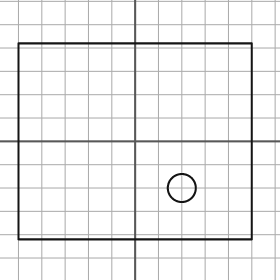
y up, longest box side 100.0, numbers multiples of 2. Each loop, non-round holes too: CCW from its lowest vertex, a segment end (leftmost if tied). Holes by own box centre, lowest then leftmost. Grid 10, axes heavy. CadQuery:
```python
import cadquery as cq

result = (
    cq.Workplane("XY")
    .moveTo(-50.0, -42.0)
    .lineTo(50.0, -42.0)
    .lineTo(50.0, 42.0)
    .lineTo(-50.0, 42.0)
    .close()
    .moveTo(20.0, -20.0)
    .circle(6.0)
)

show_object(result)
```